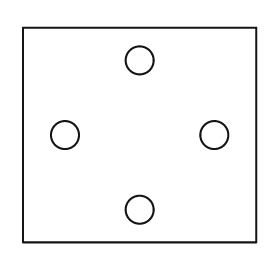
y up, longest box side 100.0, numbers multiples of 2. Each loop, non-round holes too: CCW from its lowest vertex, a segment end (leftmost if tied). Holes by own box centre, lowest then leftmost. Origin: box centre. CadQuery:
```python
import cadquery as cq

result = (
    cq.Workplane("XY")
    .moveTo(-50.0, -46.0)
    .lineTo(50.0, -46.0)
    .lineTo(50.0, 46.0)
    .lineTo(-50.0, 46.0)
    .close()
    .moveTo(0.0, -32.0)
    .circle(6.0)
    .moveTo(-32.0, 0.0)
    .circle(6.0)
    .moveTo(32.0, 0.0)
    .circle(6.0)
    .moveTo(0.0, 32.0)
    .circle(6.0)
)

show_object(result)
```